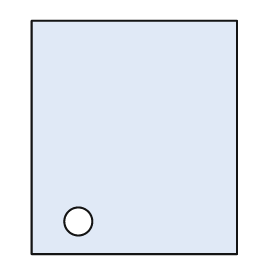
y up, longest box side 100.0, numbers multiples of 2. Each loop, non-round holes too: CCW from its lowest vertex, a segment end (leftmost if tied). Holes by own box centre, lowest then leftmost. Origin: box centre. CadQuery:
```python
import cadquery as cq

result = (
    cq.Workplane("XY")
    .moveTo(-44.0, -50.0)
    .lineTo(44.0, -50.0)
    .lineTo(44.0, 50.0)
    .lineTo(-44.0, 50.0)
    .close()
    .moveTo(-24.0, -36.0)
    .circle(6.0)
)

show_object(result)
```